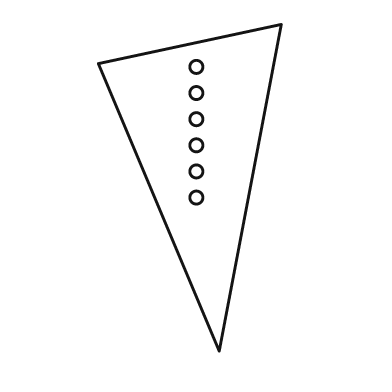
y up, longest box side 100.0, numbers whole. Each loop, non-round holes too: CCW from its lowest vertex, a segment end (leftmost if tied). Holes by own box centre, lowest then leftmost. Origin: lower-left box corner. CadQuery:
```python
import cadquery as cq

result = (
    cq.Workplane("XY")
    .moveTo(37.0, 0.0)
    .lineTo(56.0, 100.0)
    .lineTo(0.0, 88.0)
    .close()
    .moveTo(30.0, 47.0)
    .circle(2.0)
    .moveTo(30.0, 55.0)
    .circle(2.0)
    .moveTo(30.0, 63.0)
    .circle(2.0)
    .moveTo(30.0, 71.0)
    .circle(2.0)
    .moveTo(30.0, 79.0)
    .circle(2.0)
    .moveTo(30.0, 87.0)
    .circle(2.0)
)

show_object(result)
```